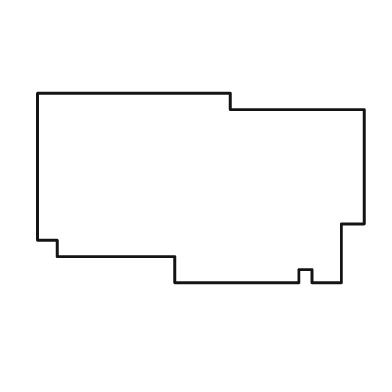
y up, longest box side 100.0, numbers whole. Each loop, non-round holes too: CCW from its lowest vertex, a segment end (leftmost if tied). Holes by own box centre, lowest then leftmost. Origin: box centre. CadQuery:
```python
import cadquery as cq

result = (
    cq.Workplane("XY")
    .moveTo(-8.0, -29.0)
    .lineTo(30.0, -29.0)
    .lineTo(30.0, -25.0)
    .lineTo(34.0, -25.0)
    .lineTo(34.0, -29.0)
    .lineTo(43.0, -29.0)
    .lineTo(43.0, -11.0)
    .lineTo(50.0, -11.0)
    .lineTo(50.0, 24.0)
    .lineTo(9.0, 24.0)
    .lineTo(9.0, 29.0)
    .lineTo(-50.0, 29.0)
    .lineTo(-50.0, -16.0)
    .lineTo(-44.0, -16.0)
    .lineTo(-44.0, -21.0)
    .lineTo(-8.0, -21.0)
    .close()
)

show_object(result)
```